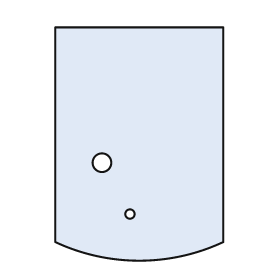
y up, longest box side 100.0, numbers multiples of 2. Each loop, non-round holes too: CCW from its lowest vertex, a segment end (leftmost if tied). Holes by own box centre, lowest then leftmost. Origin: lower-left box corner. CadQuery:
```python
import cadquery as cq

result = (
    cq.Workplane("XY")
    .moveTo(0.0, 8.0)
    .threePointArc((36.0, 0.0), (72.0, 8.0))
    .lineTo(72.0, 100.0)
    .lineTo(0.0, 100.0)
    .close()
    .moveTo(32.0, 20.0)
    .circle(2.0)
    .moveTo(20.0, 42.0)
    .circle(4.0)
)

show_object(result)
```